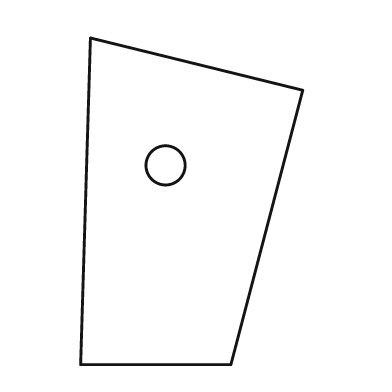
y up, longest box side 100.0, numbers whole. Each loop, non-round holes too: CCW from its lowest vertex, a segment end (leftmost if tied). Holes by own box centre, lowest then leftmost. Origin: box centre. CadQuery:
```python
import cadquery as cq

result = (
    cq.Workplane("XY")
    .moveTo(-34.0, -50.0)
    .lineTo(12.0, -50.0)
    .lineTo(34.0, 34.0)
    .lineTo(-31.0, 50.0)
    .close()
    .moveTo(-8.0, 11.0)
    .circle(6.0)
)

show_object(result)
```